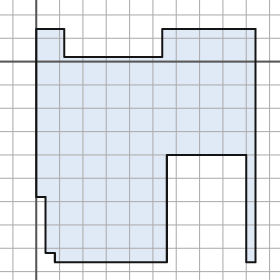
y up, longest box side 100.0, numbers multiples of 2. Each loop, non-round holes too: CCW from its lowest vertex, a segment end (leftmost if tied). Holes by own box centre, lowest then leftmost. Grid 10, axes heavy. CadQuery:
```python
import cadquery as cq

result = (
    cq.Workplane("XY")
    .moveTo(8.0, -86.0)
    .lineTo(56.0, -86.0)
    .lineTo(56.0, -40.0)
    .lineTo(90.0, -40.0)
    .lineTo(90.0, -86.0)
    .lineTo(94.0, -86.0)
    .lineTo(94.0, 14.0)
    .lineTo(54.0, 14.0)
    .lineTo(54.0, 2.0)
    .lineTo(12.0, 2.0)
    .lineTo(12.0, 14.0)
    .lineTo(0.0, 14.0)
    .lineTo(0.0, -58.0)
    .lineTo(4.0, -58.0)
    .lineTo(4.0, -82.0)
    .lineTo(8.0, -82.0)
    .close()
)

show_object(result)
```